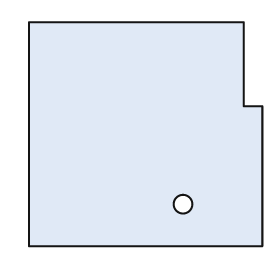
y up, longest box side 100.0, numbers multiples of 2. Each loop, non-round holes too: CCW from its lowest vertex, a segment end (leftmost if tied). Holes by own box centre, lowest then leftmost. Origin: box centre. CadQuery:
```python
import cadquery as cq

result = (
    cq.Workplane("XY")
    .moveTo(-50.0, -48.0)
    .lineTo(50.0, -48.0)
    .lineTo(50.0, 12.0)
    .lineTo(42.0, 12.0)
    .lineTo(42.0, 48.0)
    .lineTo(-50.0, 48.0)
    .close()
    .moveTo(16.0, -30.0)
    .circle(4.0)
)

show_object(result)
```